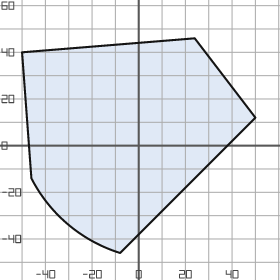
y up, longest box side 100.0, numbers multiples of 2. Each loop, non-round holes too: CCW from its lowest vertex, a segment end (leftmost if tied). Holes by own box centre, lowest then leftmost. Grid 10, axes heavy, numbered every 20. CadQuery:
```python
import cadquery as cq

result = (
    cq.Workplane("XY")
    .moveTo(-8.0, -46.0)
    .lineTo(50.0, 12.0)
    .lineTo(24.0, 46.0)
    .lineTo(-50.0, 40.0)
    .lineTo(-46.0, -14.0)
    .threePointArc((-30.0, -34.0), (-8.0, -46.0))
    .close()
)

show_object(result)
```